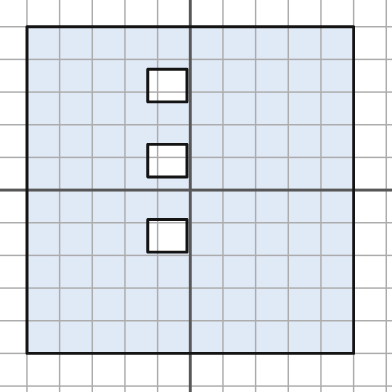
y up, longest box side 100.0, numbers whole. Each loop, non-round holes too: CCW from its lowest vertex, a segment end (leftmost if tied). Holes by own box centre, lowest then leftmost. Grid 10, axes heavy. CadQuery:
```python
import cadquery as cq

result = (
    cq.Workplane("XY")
    .moveTo(-50.0, -50.0)
    .lineTo(50.0, -50.0)
    .lineTo(50.0, 50.0)
    .lineTo(-50.0, 50.0)
    .close()
    .moveTo(-13.0, -19.0)
    .lineTo(-1.0, -19.0)
    .lineTo(-1.0, -9.0)
    .lineTo(-13.0, -9.0)
    .close()
    .moveTo(-13.0, 4.0)
    .lineTo(-1.0, 4.0)
    .lineTo(-1.0, 14.0)
    .lineTo(-13.0, 14.0)
    .close()
    .moveTo(-13.0, 27.0)
    .lineTo(-1.0, 27.0)
    .lineTo(-1.0, 37.0)
    .lineTo(-13.0, 37.0)
    .close()
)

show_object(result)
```